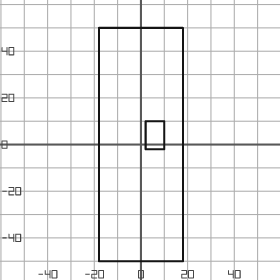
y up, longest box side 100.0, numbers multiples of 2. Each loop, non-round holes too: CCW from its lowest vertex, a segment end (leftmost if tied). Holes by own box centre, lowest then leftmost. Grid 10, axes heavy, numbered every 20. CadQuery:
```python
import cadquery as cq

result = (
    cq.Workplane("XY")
    .moveTo(-18.0, -50.0)
    .lineTo(18.0, -50.0)
    .lineTo(18.0, 50.0)
    .lineTo(-18.0, 50.0)
    .close()
    .moveTo(2.0, -2.0)
    .lineTo(10.0, -2.0)
    .lineTo(10.0, 10.0)
    .lineTo(2.0, 10.0)
    .close()
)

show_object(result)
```